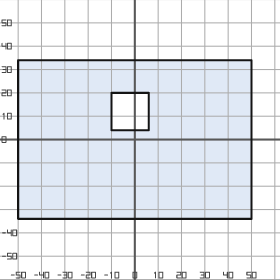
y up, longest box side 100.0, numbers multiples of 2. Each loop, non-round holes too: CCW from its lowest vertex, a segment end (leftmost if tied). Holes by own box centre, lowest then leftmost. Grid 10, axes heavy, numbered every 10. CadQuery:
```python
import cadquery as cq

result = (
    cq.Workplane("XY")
    .moveTo(-50.0, -34.0)
    .lineTo(50.0, -34.0)
    .lineTo(50.0, 34.0)
    .lineTo(-50.0, 34.0)
    .close()
    .moveTo(-10.0, 4.0)
    .lineTo(6.0, 4.0)
    .lineTo(6.0, 20.0)
    .lineTo(-10.0, 20.0)
    .close()
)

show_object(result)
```